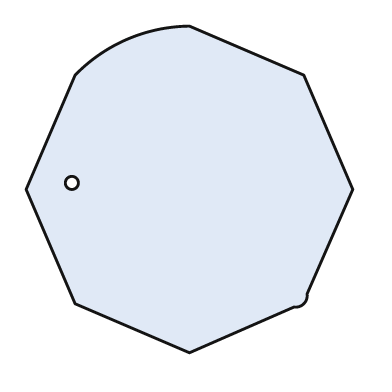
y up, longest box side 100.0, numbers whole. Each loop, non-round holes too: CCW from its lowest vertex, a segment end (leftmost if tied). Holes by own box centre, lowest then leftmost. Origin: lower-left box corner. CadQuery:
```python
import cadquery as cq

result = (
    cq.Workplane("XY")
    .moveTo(50.0, 0.0)
    .lineTo(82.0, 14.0)
    .threePointArc((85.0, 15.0), (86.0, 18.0))
    .lineTo(100.0, 50.0)
    .lineTo(85.0, 85.0)
    .lineTo(50.0, 100.0)
    .threePointArc((31.0, 96.0), (15.0, 85.0))
    .lineTo(0.0, 50.0)
    .lineTo(15.0, 15.0)
    .close()
    .moveTo(14.0, 52.0)
    .circle(2.0)
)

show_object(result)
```